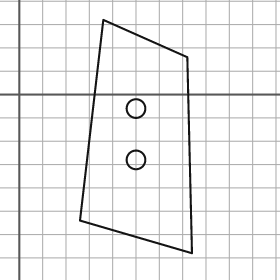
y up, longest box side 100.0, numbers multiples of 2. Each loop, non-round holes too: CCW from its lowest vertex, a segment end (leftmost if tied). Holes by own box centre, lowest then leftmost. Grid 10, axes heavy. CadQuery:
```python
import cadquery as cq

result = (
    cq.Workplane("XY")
    .moveTo(74.0, -68.0)
    .lineTo(72.0, 16.0)
    .lineTo(36.0, 32.0)
    .lineTo(26.0, -54.0)
    .close()
    .moveTo(50.0, -28.0)
    .circle(4.0)
    .moveTo(50.0, -6.0)
    .circle(4.0)
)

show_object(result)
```